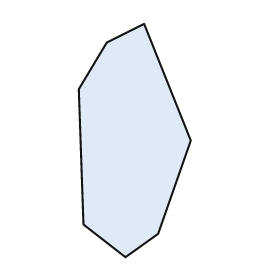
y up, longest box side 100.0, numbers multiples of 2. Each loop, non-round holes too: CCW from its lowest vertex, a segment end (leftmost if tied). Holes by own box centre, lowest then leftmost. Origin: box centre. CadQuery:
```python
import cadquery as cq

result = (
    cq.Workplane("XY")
    .moveTo(-4.0, -50.0)
    .lineTo(10.0, -40.0)
    .lineTo(24.0, 0.0)
    .lineTo(4.0, 50.0)
    .lineTo(-12.0, 42.0)
    .lineTo(-24.0, 22.0)
    .lineTo(-22.0, -36.0)
    .close()
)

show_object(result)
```